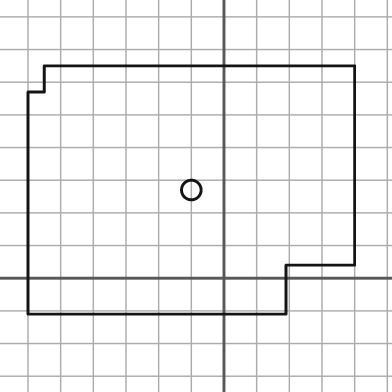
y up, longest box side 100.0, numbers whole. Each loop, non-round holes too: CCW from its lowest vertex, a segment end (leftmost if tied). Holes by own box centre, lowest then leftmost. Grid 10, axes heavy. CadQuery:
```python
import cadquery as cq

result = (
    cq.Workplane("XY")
    .moveTo(-60.0, -11.0)
    .lineTo(19.0, -11.0)
    .lineTo(19.0, 4.0)
    .lineTo(40.0, 4.0)
    .lineTo(40.0, 65.0)
    .lineTo(-55.0, 65.0)
    .lineTo(-55.0, 57.0)
    .lineTo(-60.0, 57.0)
    .close()
    .moveTo(-10.0, 27.0)
    .circle(3.0)
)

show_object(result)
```